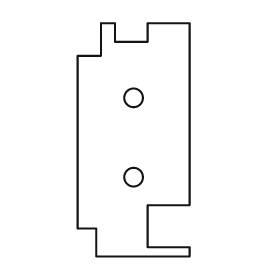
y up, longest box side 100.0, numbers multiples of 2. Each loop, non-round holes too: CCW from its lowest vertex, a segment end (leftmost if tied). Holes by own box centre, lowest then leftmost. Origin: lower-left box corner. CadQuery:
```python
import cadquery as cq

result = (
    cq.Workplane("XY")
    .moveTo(8.0, 0.0)
    .lineTo(48.0, 0.0)
    .lineTo(48.0, 4.0)
    .lineTo(30.0, 4.0)
    .lineTo(30.0, 22.0)
    .lineTo(48.0, 22.0)
    .lineTo(48.0, 100.0)
    .lineTo(30.0, 100.0)
    .lineTo(30.0, 92.0)
    .lineTo(16.0, 92.0)
    .lineTo(16.0, 100.0)
    .lineTo(10.0, 100.0)
    .lineTo(10.0, 86.0)
    .lineTo(0.0, 86.0)
    .lineTo(0.0, 12.0)
    .lineTo(8.0, 12.0)
    .close()
    .moveTo(24.0, 34.0)
    .circle(4.0)
    .moveTo(24.0, 68.0)
    .circle(4.0)
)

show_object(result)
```